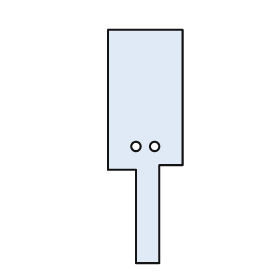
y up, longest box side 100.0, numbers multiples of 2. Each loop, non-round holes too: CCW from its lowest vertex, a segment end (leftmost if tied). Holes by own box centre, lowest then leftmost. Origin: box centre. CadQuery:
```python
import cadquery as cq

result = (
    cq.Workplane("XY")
    .moveTo(-4.0, -50.0)
    .lineTo(6.0, -50.0)
    .lineTo(6.0, -8.0)
    .lineTo(16.0, -8.0)
    .lineTo(16.0, 50.0)
    .lineTo(-16.0, 50.0)
    .lineTo(-16.0, -10.0)
    .lineTo(-4.0, -10.0)
    .close()
    .moveTo(-4.0, 0.0)
    .circle(2.0)
    .moveTo(4.0, 0.0)
    .circle(2.0)
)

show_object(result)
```